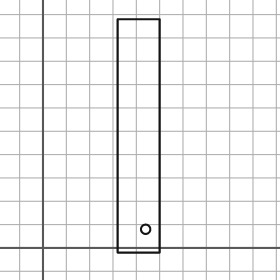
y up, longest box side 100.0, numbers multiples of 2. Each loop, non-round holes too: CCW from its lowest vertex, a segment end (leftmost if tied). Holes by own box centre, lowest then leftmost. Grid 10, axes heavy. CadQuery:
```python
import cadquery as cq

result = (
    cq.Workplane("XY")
    .moveTo(32.0, -2.0)
    .lineTo(50.0, -2.0)
    .lineTo(50.0, 98.0)
    .lineTo(32.0, 98.0)
    .close()
    .moveTo(44.0, 8.0)
    .circle(2.0)
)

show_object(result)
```